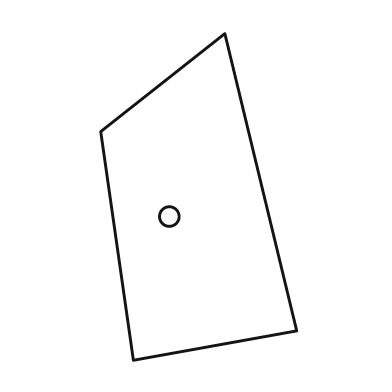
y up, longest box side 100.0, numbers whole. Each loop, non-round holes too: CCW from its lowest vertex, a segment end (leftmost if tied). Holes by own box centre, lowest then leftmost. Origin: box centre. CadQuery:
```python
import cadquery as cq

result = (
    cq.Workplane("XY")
    .moveTo(-20.0, -50.0)
    .lineTo(30.0, -41.0)
    .lineTo(8.0, 50.0)
    .lineTo(-30.0, 20.0)
    .close()
    .moveTo(-9.0, -6.0)
    .circle(3.0)
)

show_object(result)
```